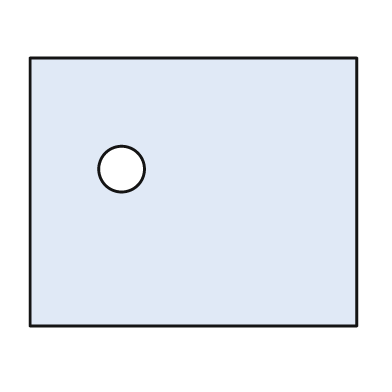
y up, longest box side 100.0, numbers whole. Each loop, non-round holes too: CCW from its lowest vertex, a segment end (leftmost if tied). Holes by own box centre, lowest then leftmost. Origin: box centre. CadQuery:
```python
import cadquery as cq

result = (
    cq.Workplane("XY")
    .moveTo(-50.0, -41.0)
    .lineTo(50.0, -41.0)
    .lineTo(50.0, 41.0)
    .lineTo(-50.0, 41.0)
    .close()
    .moveTo(-22.0, 7.0)
    .circle(7.0)
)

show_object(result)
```